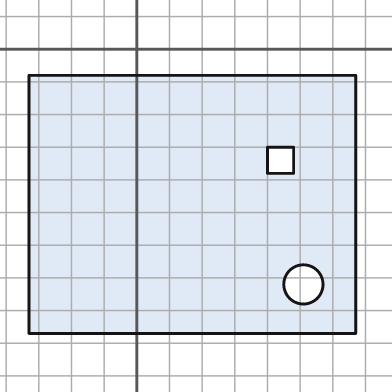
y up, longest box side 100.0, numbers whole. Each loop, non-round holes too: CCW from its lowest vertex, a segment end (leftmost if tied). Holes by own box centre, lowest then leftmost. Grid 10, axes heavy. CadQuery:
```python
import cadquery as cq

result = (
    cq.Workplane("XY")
    .moveTo(-33.0, -87.0)
    .lineTo(67.0, -87.0)
    .lineTo(67.0, -8.0)
    .lineTo(-33.0, -8.0)
    .close()
    .moveTo(51.0, -72.0)
    .circle(6.0)
    .moveTo(40.0, -38.0)
    .lineTo(48.0, -38.0)
    .lineTo(48.0, -30.0)
    .lineTo(40.0, -30.0)
    .close()
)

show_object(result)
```